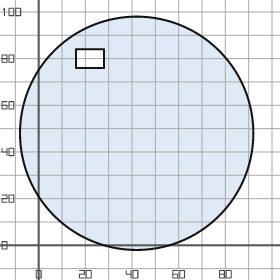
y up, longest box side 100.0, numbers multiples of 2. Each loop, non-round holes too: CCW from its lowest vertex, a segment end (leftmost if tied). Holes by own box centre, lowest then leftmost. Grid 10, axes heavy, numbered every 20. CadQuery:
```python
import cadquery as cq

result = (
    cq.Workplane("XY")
    .moveTo(42.0, 48.0)
    .circle(50.0)
    .moveTo(16.0, 76.0)
    .lineTo(28.0, 76.0)
    .lineTo(28.0, 84.0)
    .lineTo(16.0, 84.0)
    .close()
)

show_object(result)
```